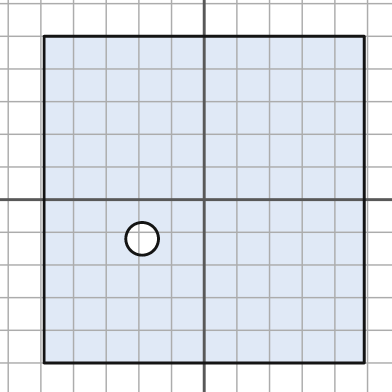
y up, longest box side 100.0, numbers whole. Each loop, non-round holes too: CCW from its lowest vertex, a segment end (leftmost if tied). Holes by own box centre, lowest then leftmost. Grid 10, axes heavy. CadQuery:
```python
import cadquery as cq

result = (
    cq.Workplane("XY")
    .moveTo(-49.0, -50.0)
    .lineTo(49.0, -50.0)
    .lineTo(49.0, 50.0)
    .lineTo(-49.0, 50.0)
    .close()
    .moveTo(-19.0, -12.0)
    .circle(5.0)
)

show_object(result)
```